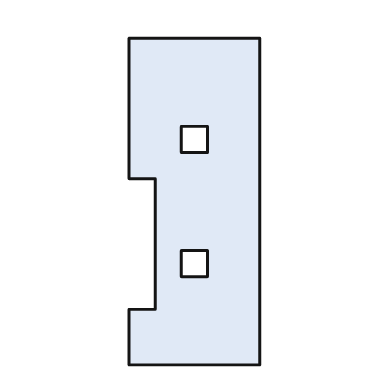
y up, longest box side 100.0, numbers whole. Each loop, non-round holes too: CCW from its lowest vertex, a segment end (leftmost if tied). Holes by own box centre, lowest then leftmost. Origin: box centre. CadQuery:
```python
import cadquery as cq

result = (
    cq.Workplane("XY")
    .moveTo(-20.0, -50.0)
    .lineTo(20.0, -50.0)
    .lineTo(20.0, 50.0)
    .lineTo(-20.0, 50.0)
    .lineTo(-20.0, 7.0)
    .lineTo(-12.0, 7.0)
    .lineTo(-12.0, -33.0)
    .lineTo(-20.0, -33.0)
    .close()
    .moveTo(-4.0, -23.0)
    .lineTo(4.0, -23.0)
    .lineTo(4.0, -15.0)
    .lineTo(-4.0, -15.0)
    .close()
    .moveTo(-4.0, 15.0)
    .lineTo(4.0, 15.0)
    .lineTo(4.0, 23.0)
    .lineTo(-4.0, 23.0)
    .close()
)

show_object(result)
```